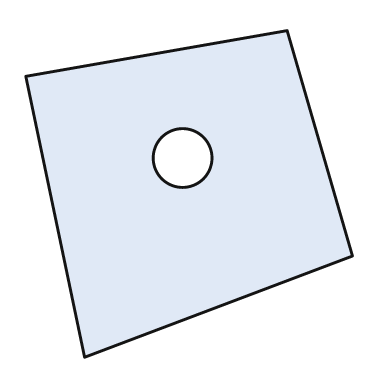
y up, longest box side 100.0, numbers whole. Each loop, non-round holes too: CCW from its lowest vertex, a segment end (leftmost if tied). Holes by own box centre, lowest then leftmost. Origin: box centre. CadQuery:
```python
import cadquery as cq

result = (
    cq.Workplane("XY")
    .moveTo(-32.0, -50.0)
    .lineTo(50.0, -19.0)
    .lineTo(30.0, 50.0)
    .lineTo(-50.0, 36.0)
    .close()
    .moveTo(-2.0, 11.0)
    .circle(9.0)
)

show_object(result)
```